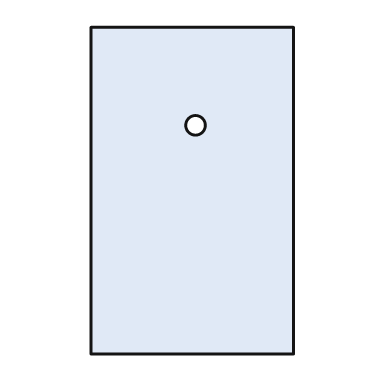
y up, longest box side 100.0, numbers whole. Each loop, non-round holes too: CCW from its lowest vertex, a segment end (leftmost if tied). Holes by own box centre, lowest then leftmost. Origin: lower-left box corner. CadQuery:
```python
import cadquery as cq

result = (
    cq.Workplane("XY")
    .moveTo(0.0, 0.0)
    .lineTo(62.0, 0.0)
    .lineTo(62.0, 100.0)
    .lineTo(0.0, 100.0)
    .close()
    .moveTo(32.0, 70.0)
    .circle(3.0)
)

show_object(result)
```